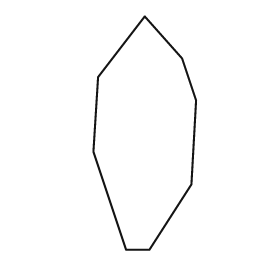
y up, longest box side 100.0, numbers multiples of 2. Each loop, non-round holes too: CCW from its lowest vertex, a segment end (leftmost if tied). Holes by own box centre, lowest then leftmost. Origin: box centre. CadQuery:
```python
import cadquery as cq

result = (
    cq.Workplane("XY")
    .moveTo(-8.0, -50.0)
    .lineTo(2.0, -50.0)
    .lineTo(20.0, -22.0)
    .lineTo(22.0, 14.0)
    .lineTo(16.0, 32.0)
    .lineTo(0.0, 50.0)
    .lineTo(-20.0, 24.0)
    .lineTo(-22.0, -8.0)
    .close()
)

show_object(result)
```